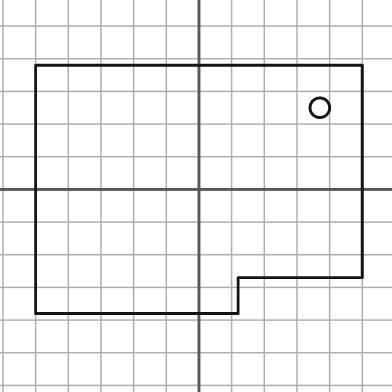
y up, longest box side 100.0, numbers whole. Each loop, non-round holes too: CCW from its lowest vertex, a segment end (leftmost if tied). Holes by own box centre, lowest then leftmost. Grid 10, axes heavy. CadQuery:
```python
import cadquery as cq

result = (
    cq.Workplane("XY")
    .moveTo(-50.0, -38.0)
    .lineTo(12.0, -38.0)
    .lineTo(12.0, -27.0)
    .lineTo(50.0, -27.0)
    .lineTo(50.0, 38.0)
    .lineTo(-50.0, 38.0)
    .close()
    .moveTo(37.0, 25.0)
    .circle(3.0)
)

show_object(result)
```